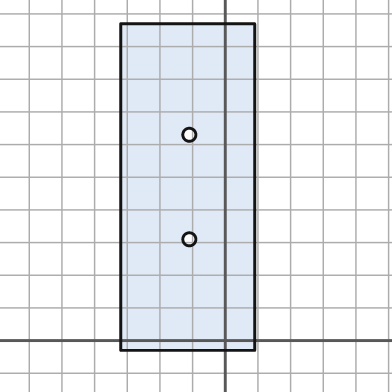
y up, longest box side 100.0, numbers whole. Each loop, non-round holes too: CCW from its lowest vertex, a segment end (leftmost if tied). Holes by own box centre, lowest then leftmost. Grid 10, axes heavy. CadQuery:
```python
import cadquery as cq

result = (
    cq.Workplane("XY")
    .moveTo(-32.0, -3.0)
    .lineTo(9.0, -3.0)
    .lineTo(9.0, 97.0)
    .lineTo(-32.0, 97.0)
    .close()
    .moveTo(-11.0, 31.0)
    .circle(2.0)
    .moveTo(-11.0, 63.0)
    .circle(2.0)
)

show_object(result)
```